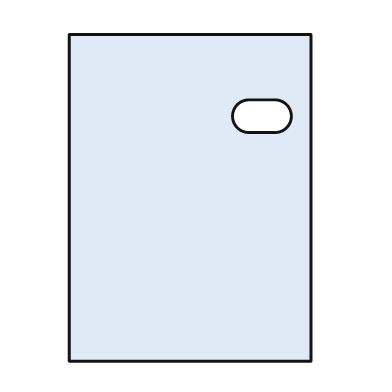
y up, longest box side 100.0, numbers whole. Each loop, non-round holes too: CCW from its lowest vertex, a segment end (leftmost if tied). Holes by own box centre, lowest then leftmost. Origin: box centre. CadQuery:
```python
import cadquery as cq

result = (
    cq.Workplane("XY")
    .moveTo(-37.0, -50.0)
    .lineTo(37.0, -50.0)
    .lineTo(37.0, 50.0)
    .lineTo(-37.0, 50.0)
    .close()
    .moveTo(18.0, 20.0)
    .lineTo(26.0, 20.0)
    .threePointArc((31.0, 25.0), (26.0, 30.0))
    .lineTo(18.0, 30.0)
    .threePointArc((13.0, 25.0), (18.0, 20.0))
    .close()
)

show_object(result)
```